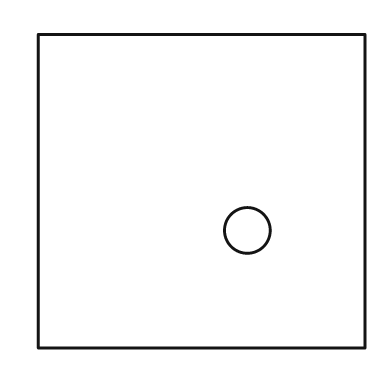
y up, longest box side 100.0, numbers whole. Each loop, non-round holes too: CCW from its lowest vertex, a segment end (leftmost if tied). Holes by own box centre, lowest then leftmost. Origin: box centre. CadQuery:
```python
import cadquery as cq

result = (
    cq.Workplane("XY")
    .moveTo(-50.0, -48.0)
    .lineTo(50.0, -48.0)
    .lineTo(50.0, 48.0)
    .lineTo(-50.0, 48.0)
    .close()
    .moveTo(14.0, -12.0)
    .circle(7.0)
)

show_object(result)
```